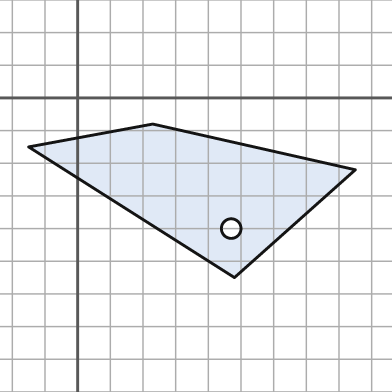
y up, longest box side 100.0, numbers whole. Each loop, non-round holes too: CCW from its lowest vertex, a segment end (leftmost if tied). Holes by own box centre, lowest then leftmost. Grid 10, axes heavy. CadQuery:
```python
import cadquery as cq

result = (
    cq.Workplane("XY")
    .moveTo(48.0, -55.0)
    .lineTo(85.0, -22.0)
    .lineTo(23.0, -8.0)
    .lineTo(-15.0, -15.0)
    .close()
    .moveTo(47.0, -40.0)
    .circle(3.0)
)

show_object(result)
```